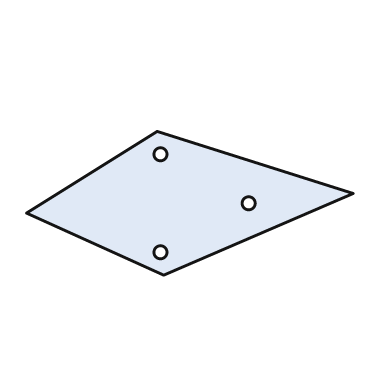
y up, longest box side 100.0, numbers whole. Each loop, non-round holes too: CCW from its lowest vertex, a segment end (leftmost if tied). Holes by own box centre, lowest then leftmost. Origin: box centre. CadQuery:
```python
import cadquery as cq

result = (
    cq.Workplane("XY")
    .moveTo(-8.0, -22.0)
    .lineTo(50.0, 3.0)
    .lineTo(-10.0, 22.0)
    .lineTo(-50.0, -3.0)
    .close()
    .moveTo(-9.0, -15.0)
    .circle(2.0)
    .moveTo(18.0, 0.0)
    .circle(2.0)
    .moveTo(-9.0, 15.0)
    .circle(2.0)
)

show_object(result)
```